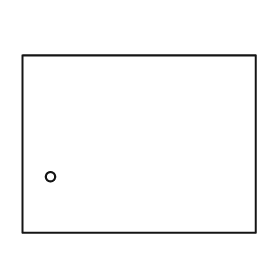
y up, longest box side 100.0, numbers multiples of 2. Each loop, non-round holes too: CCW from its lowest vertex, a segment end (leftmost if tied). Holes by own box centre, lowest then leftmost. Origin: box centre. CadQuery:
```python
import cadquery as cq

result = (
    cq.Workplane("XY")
    .moveTo(-50.0, -38.0)
    .lineTo(50.0, -38.0)
    .lineTo(50.0, 38.0)
    .lineTo(-50.0, 38.0)
    .close()
    .moveTo(-38.0, -14.0)
    .circle(2.0)
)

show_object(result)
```